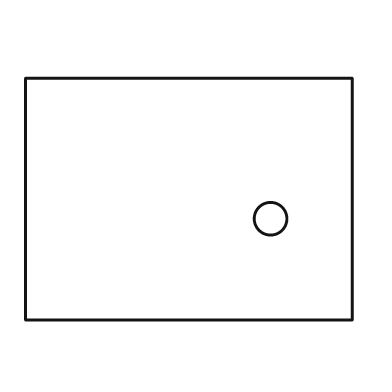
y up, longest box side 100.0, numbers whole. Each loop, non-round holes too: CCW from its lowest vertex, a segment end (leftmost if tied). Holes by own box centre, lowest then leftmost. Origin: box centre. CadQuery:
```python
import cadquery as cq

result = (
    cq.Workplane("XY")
    .moveTo(-50.0, -37.0)
    .lineTo(50.0, -37.0)
    .lineTo(50.0, 37.0)
    .lineTo(-50.0, 37.0)
    .close()
    .moveTo(25.0, -6.0)
    .circle(5.0)
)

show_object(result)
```